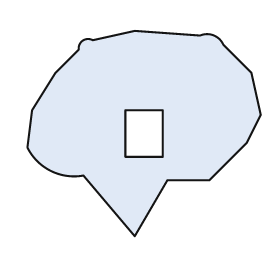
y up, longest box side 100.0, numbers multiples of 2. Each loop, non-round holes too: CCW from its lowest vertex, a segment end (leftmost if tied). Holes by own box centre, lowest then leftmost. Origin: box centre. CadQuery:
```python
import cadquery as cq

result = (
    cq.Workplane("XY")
    .moveTo(-4.0, -44.0)
    .lineTo(10.0, -20.0)
    .lineTo(28.0, -20.0)
    .lineTo(44.0, -4.0)
    .lineTo(50.0, 8.0)
    .lineTo(46.0, 26.0)
    .lineTo(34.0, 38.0)
    .threePointArc((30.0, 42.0), (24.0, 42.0))
    .lineTo(-4.0, 44.0)
    .lineTo(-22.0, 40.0)
    .threePointArc((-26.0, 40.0), (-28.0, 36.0))
    .lineTo(-38.0, 26.0)
    .lineTo(-48.0, 10.0)
    .lineTo(-50.0, -6.0)
    .threePointArc((-40.0, -16.0), (-26.0, -18.0))
    .close()
    .moveTo(-8.0, -10.0)
    .lineTo(8.0, -10.0)
    .lineTo(8.0, 10.0)
    .lineTo(-8.0, 10.0)
    .close()
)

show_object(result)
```